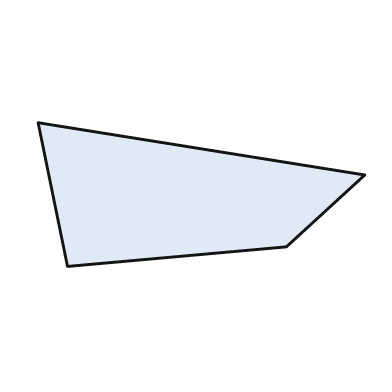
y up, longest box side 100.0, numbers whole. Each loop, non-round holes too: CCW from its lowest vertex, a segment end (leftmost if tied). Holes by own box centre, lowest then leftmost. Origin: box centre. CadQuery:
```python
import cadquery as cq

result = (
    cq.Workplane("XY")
    .moveTo(-41.0, -22.0)
    .lineTo(26.0, -16.0)
    .lineTo(50.0, 6.0)
    .lineTo(-50.0, 22.0)
    .close()
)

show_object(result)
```